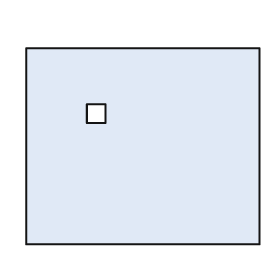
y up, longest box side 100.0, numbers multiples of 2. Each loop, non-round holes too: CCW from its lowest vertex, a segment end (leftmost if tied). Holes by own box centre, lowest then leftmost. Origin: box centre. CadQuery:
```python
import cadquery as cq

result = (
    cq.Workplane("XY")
    .moveTo(-50.0, -42.0)
    .lineTo(50.0, -42.0)
    .lineTo(50.0, 42.0)
    .lineTo(-50.0, 42.0)
    .close()
    .moveTo(-24.0, 10.0)
    .lineTo(-16.0, 10.0)
    .lineTo(-16.0, 18.0)
    .lineTo(-24.0, 18.0)
    .close()
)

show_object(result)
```